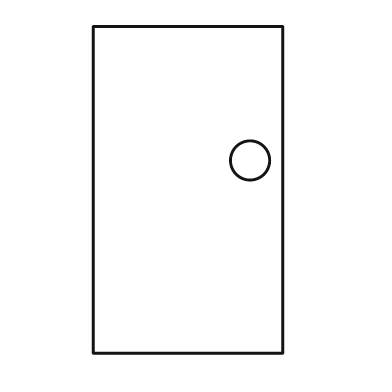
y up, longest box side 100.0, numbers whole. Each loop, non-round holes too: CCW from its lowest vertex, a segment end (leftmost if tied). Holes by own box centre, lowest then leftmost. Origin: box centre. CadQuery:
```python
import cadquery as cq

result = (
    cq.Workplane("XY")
    .moveTo(-29.0, -50.0)
    .lineTo(29.0, -50.0)
    .lineTo(29.0, 50.0)
    .lineTo(-29.0, 50.0)
    .close()
    .moveTo(19.0, 9.0)
    .circle(6.0)
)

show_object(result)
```